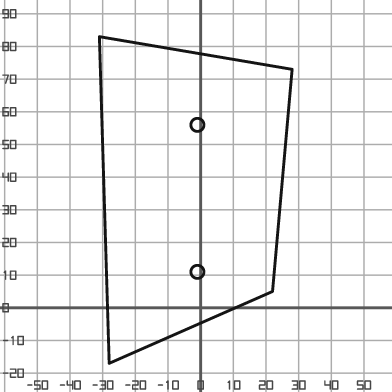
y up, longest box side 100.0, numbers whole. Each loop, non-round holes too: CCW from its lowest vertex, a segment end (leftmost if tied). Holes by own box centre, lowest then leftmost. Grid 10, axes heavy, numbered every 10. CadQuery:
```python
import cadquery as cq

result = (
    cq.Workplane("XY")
    .moveTo(-28.0, -17.0)
    .lineTo(22.0, 5.0)
    .lineTo(28.0, 73.0)
    .lineTo(-31.0, 83.0)
    .close()
    .moveTo(-1.0, 11.0)
    .circle(2.0)
    .moveTo(-1.0, 56.0)
    .circle(2.0)
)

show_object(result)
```